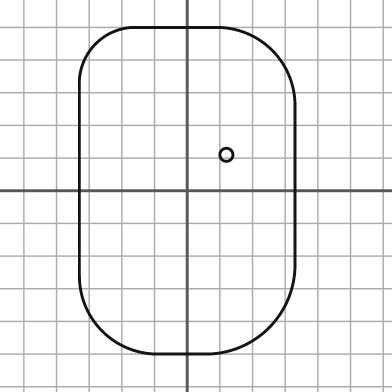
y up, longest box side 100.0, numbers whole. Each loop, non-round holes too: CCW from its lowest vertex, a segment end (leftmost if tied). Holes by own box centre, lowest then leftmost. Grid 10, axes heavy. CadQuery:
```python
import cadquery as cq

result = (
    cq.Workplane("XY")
    .moveTo(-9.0, -50.0)
    .lineTo(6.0, -50.0)
    .threePointArc((25.0, -42.0), (33.0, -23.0))
    .lineTo(33.0, 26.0)
    .threePointArc((26.0, 43.0), (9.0, 50.0))
    .lineTo(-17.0, 50.0)
    .threePointArc((-28.0, 45.0), (-33.0, 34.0))
    .lineTo(-33.0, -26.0)
    .threePointArc((-26.0, -43.0), (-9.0, -50.0))
    .close()
    .moveTo(12.0, 11.0)
    .circle(2.0)
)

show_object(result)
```